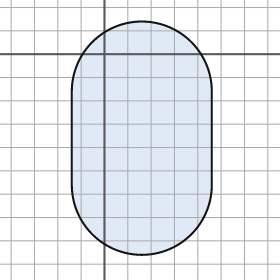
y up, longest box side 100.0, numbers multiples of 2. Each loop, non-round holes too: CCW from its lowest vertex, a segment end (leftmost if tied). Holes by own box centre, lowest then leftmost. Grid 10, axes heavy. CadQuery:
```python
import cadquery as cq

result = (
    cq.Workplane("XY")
    .moveTo(-14.0, -56.0)
    .threePointArc((16.0, -86.0), (46.0, -56.0))
    .lineTo(46.0, -16.0)
    .threePointArc((16.0, 14.0), (-14.0, -16.0))
    .close()
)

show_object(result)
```